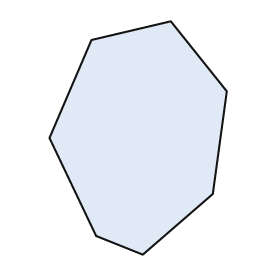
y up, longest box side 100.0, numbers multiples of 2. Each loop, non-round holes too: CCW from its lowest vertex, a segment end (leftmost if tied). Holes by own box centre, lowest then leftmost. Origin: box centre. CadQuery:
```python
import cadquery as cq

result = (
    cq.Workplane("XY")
    .moveTo(2.0, -50.0)
    .lineTo(32.0, -24.0)
    .lineTo(38.0, 20.0)
    .lineTo(14.0, 50.0)
    .lineTo(-20.0, 42.0)
    .lineTo(-38.0, 0.0)
    .lineTo(-18.0, -42.0)
    .close()
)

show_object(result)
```